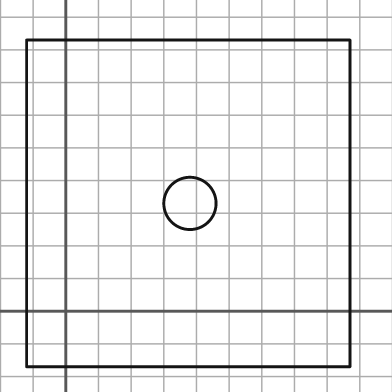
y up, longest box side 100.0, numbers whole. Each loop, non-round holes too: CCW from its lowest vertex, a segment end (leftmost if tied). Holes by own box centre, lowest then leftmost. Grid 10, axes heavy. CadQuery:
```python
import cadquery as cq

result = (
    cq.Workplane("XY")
    .moveTo(-12.0, -17.0)
    .lineTo(87.0, -17.0)
    .lineTo(87.0, 83.0)
    .lineTo(-12.0, 83.0)
    .close()
    .moveTo(38.0, 33.0)
    .circle(8.0)
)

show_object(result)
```